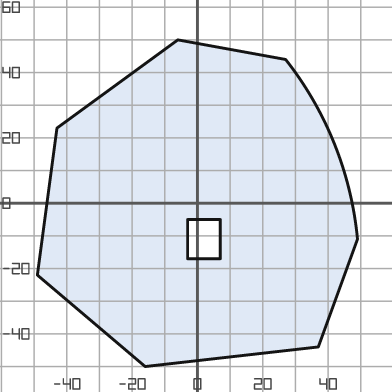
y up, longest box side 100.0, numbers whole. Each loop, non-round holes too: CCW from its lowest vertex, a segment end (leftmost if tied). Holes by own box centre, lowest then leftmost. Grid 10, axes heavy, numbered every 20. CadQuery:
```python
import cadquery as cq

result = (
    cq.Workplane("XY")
    .moveTo(-16.0, -50.0)
    .lineTo(37.0, -44.0)
    .lineTo(49.0, -11.0)
    .threePointArc((42.0, 18.0), (27.0, 44.0))
    .lineTo(-6.0, 50.0)
    .lineTo(-43.0, 23.0)
    .lineTo(-49.0, -22.0)
    .close()
    .moveTo(-3.0, -17.0)
    .lineTo(7.0, -17.0)
    .lineTo(7.0, -5.0)
    .lineTo(-3.0, -5.0)
    .close()
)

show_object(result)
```